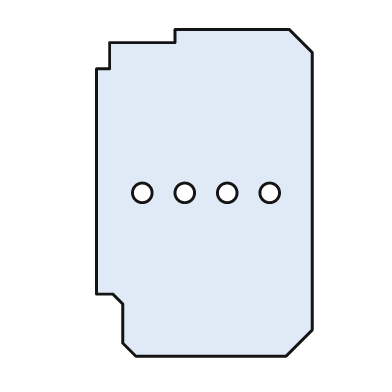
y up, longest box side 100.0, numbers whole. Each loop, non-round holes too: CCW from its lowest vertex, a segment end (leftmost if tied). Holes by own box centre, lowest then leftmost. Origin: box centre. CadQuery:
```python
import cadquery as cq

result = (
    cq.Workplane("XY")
    .moveTo(-21.0, -50.0)
    .lineTo(25.0, -50.0)
    .lineTo(33.0, -42.0)
    .lineTo(33.0, 43.0)
    .lineTo(26.0, 50.0)
    .lineTo(-9.0, 50.0)
    .lineTo(-9.0, 46.0)
    .lineTo(-29.0, 46.0)
    .lineTo(-29.0, 38.0)
    .lineTo(-33.0, 38.0)
    .lineTo(-33.0, -31.0)
    .lineTo(-28.0, -31.0)
    .lineTo(-25.0, -34.0)
    .lineTo(-25.0, -46.0)
    .close()
    .moveTo(-19.0, 0.0)
    .circle(3.0)
    .moveTo(-6.0, 0.0)
    .circle(3.0)
    .moveTo(7.0, 0.0)
    .circle(3.0)
    .moveTo(20.0, 0.0)
    .circle(3.0)
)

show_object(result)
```